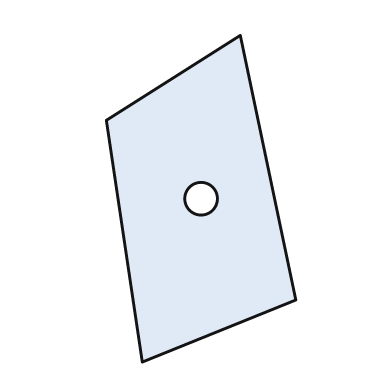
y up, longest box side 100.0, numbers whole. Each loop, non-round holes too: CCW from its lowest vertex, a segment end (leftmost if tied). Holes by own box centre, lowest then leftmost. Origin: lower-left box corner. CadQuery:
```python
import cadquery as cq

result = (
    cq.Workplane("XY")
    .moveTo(11.0, 0.0)
    .lineTo(58.0, 19.0)
    .lineTo(41.0, 100.0)
    .lineTo(0.0, 74.0)
    .close()
    .moveTo(29.0, 50.0)
    .circle(5.0)
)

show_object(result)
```